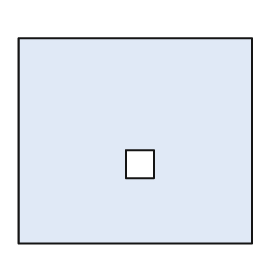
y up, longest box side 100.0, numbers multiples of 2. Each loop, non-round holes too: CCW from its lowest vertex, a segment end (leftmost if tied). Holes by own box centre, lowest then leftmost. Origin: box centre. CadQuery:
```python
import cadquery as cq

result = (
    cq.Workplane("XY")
    .moveTo(-50.0, -44.0)
    .lineTo(50.0, -44.0)
    .lineTo(50.0, 44.0)
    .lineTo(-50.0, 44.0)
    .close()
    .moveTo(-4.0, -16.0)
    .lineTo(8.0, -16.0)
    .lineTo(8.0, -4.0)
    .lineTo(-4.0, -4.0)
    .close()
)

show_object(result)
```